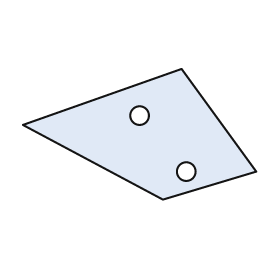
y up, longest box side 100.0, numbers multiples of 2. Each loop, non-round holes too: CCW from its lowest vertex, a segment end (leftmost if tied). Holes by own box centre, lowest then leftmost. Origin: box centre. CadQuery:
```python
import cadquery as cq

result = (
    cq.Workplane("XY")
    .moveTo(10.0, -28.0)
    .lineTo(50.0, -16.0)
    .lineTo(18.0, 28.0)
    .lineTo(-50.0, 4.0)
    .close()
    .moveTo(20.0, -16.0)
    .circle(4.0)
    .moveTo(0.0, 8.0)
    .circle(4.0)
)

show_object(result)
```